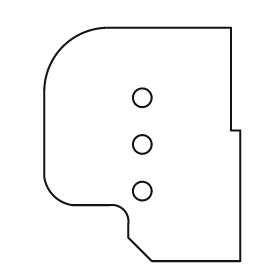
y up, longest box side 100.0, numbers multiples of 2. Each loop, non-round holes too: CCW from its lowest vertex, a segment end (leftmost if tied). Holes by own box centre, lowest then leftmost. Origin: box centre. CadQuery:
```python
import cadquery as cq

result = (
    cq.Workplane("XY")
    .moveTo(4.0, -50.0)
    .lineTo(42.0, -50.0)
    .lineTo(42.0, 6.0)
    .lineTo(38.0, 6.0)
    .lineTo(38.0, 50.0)
    .lineTo(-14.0, 50.0)
    .threePointArc((-34.0, 42.0), (-42.0, 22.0))
    .lineTo(-42.0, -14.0)
    .threePointArc((-38.0, -22.0), (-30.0, -26.0))
    .lineTo(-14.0, -26.0)
    .threePointArc((-8.0, -28.0), (-6.0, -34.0))
    .lineTo(-6.0, -40.0)
    .close()
    .moveTo(0.0, -20.0)
    .circle(4.0)
    .moveTo(0.0, 0.0)
    .circle(4.0)
    .moveTo(0.0, 20.0)
    .circle(4.0)
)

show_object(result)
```